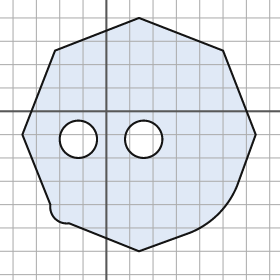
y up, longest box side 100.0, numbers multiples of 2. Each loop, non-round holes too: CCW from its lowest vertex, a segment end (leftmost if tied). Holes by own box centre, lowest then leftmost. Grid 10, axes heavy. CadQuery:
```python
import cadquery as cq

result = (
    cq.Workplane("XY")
    .moveTo(14.0, -60.0)
    .lineTo(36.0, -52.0)
    .threePointArc((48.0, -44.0), (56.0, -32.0))
    .lineTo(64.0, -10.0)
    .lineTo(50.0, 26.0)
    .lineTo(14.0, 40.0)
    .lineTo(-22.0, 26.0)
    .lineTo(-36.0, -10.0)
    .lineTo(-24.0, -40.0)
    .threePointArc((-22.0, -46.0), (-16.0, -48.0))
    .close()
    .moveTo(-12.0, -12.0)
    .circle(8.0)
    .moveTo(16.0, -12.0)
    .circle(8.0)
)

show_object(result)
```